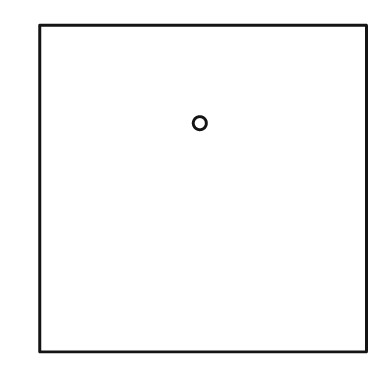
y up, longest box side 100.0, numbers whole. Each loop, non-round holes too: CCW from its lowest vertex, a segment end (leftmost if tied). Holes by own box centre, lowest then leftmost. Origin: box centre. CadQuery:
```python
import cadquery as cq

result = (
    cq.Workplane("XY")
    .moveTo(-50.0, -50.0)
    .lineTo(50.0, -50.0)
    .lineTo(50.0, 50.0)
    .lineTo(-50.0, 50.0)
    .close()
    .moveTo(-1.0, 20.0)
    .circle(2.0)
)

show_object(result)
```